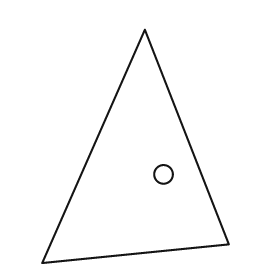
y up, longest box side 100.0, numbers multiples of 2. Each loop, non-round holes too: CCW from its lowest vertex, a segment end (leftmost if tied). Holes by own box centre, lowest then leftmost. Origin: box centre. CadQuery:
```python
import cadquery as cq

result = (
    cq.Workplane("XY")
    .moveTo(-40.0, -50.0)
    .lineTo(40.0, -42.0)
    .lineTo(4.0, 50.0)
    .close()
    .moveTo(12.0, -12.0)
    .circle(4.0)
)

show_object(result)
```